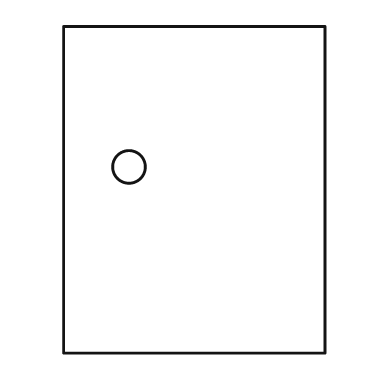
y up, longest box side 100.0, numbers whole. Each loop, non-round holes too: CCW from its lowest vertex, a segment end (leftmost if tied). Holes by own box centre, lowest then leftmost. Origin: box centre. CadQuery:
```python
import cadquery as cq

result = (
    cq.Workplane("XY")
    .moveTo(-40.0, -50.0)
    .lineTo(40.0, -50.0)
    .lineTo(40.0, 50.0)
    .lineTo(-40.0, 50.0)
    .close()
    .moveTo(-20.0, 7.0)
    .circle(5.0)
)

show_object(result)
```